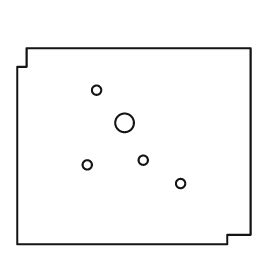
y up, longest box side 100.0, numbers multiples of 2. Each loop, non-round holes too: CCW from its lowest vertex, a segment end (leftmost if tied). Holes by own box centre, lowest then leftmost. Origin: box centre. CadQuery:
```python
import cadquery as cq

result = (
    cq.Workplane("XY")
    .moveTo(-50.0, -42.0)
    .lineTo(40.0, -42.0)
    .lineTo(40.0, -38.0)
    .lineTo(50.0, -38.0)
    .lineTo(50.0, 42.0)
    .lineTo(-46.0, 42.0)
    .lineTo(-46.0, 34.0)
    .lineTo(-50.0, 34.0)
    .close()
    .moveTo(20.0, -16.0)
    .circle(2.0)
    .moveTo(-20.0, -8.0)
    .circle(2.0)
    .moveTo(4.0, -6.0)
    .circle(2.0)
    .moveTo(-4.0, 10.0)
    .circle(4.0)
    .moveTo(-16.0, 24.0)
    .circle(2.0)
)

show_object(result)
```